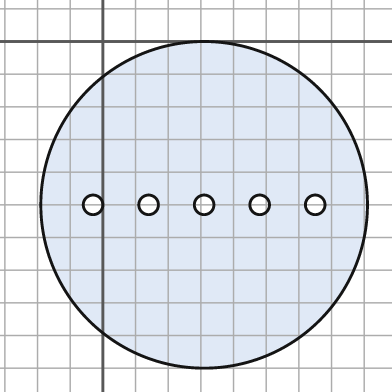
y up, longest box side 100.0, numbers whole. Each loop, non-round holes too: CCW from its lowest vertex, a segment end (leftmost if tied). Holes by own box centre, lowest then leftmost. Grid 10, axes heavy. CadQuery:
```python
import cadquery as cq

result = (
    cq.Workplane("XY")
    .moveTo(31.0, -50.0)
    .circle(50.0)
    .moveTo(-3.0, -50.0)
    .circle(3.0)
    .moveTo(14.0, -50.0)
    .circle(3.0)
    .moveTo(31.0, -50.0)
    .circle(3.0)
    .moveTo(48.0, -50.0)
    .circle(3.0)
    .moveTo(65.0, -50.0)
    .circle(3.0)
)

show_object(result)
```